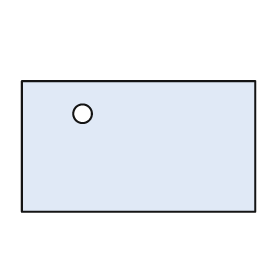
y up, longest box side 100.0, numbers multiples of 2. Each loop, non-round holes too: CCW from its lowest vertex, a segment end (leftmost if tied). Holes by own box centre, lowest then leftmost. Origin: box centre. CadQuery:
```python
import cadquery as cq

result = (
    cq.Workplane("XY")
    .moveTo(-50.0, -28.0)
    .lineTo(50.0, -28.0)
    .lineTo(50.0, 28.0)
    .lineTo(-50.0, 28.0)
    .close()
    .moveTo(-24.0, 14.0)
    .circle(4.0)
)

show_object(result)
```